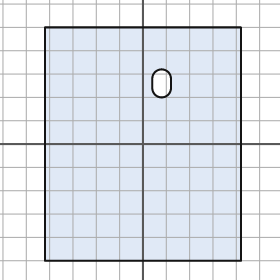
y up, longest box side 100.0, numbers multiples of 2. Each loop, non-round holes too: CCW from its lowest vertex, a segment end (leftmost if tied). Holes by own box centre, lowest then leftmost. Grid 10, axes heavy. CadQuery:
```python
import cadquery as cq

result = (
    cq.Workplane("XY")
    .moveTo(-42.0, -50.0)
    .lineTo(42.0, -50.0)
    .lineTo(42.0, 50.0)
    .lineTo(-42.0, 50.0)
    .close()
    .moveTo(4.0, 24.0)
    .threePointArc((8.0, 20.0), (12.0, 24.0))
    .lineTo(12.0, 28.0)
    .threePointArc((8.0, 32.0), (4.0, 28.0))
    .close()
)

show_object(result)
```